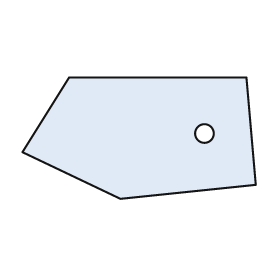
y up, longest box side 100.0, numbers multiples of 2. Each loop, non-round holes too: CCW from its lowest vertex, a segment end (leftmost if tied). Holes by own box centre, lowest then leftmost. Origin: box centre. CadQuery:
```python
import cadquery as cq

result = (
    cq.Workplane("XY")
    .moveTo(-8.0, -26.0)
    .lineTo(50.0, -20.0)
    .lineTo(46.0, 26.0)
    .lineTo(-30.0, 26.0)
    .lineTo(-50.0, -6.0)
    .close()
    .moveTo(28.0, 2.0)
    .circle(4.0)
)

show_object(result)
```